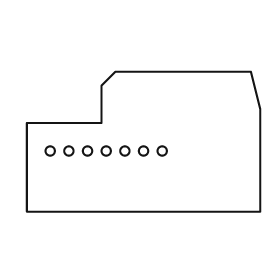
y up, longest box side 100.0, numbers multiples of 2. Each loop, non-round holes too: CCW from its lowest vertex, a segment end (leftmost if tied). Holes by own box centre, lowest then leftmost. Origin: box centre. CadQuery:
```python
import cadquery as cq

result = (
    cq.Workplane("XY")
    .moveTo(-50.0, -30.0)
    .lineTo(50.0, -30.0)
    .lineTo(50.0, 14.0)
    .lineTo(46.0, 30.0)
    .lineTo(-12.0, 30.0)
    .lineTo(-18.0, 24.0)
    .lineTo(-18.0, 8.0)
    .lineTo(-50.0, 8.0)
    .close()
    .moveTo(-40.0, -4.0)
    .circle(2.0)
    .moveTo(-32.0, -4.0)
    .circle(2.0)
    .moveTo(-24.0, -4.0)
    .circle(2.0)
    .moveTo(-16.0, -4.0)
    .circle(2.0)
    .moveTo(-8.0, -4.0)
    .circle(2.0)
    .moveTo(0.0, -4.0)
    .circle(2.0)
    .moveTo(8.0, -4.0)
    .circle(2.0)
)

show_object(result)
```